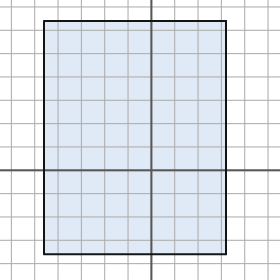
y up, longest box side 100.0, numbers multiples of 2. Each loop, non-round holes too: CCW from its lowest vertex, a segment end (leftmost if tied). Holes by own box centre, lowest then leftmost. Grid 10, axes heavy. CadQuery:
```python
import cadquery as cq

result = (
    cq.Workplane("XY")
    .moveTo(-46.0, -36.0)
    .lineTo(32.0, -36.0)
    .lineTo(32.0, 64.0)
    .lineTo(-46.0, 64.0)
    .close()
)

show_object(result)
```